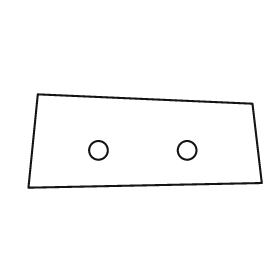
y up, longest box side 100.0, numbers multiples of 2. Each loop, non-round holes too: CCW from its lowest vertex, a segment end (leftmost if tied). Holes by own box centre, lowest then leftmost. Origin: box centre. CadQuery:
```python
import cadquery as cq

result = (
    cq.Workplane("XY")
    .moveTo(-50.0, -20.0)
    .lineTo(50.0, -18.0)
    .lineTo(46.0, 16.0)
    .lineTo(-46.0, 20.0)
    .close()
    .moveTo(-20.0, -4.0)
    .circle(4.0)
    .moveTo(18.0, -4.0)
    .circle(4.0)
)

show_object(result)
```